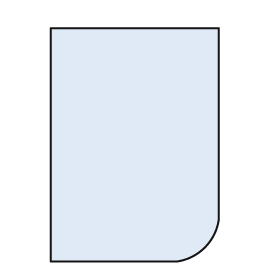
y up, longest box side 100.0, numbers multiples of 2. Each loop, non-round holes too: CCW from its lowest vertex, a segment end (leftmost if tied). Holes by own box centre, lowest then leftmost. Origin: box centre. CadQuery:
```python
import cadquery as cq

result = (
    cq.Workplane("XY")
    .moveTo(-36.0, -50.0)
    .lineTo(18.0, -50.0)
    .threePointArc((30.0, -44.0), (36.0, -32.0))
    .lineTo(36.0, 50.0)
    .lineTo(-36.0, 50.0)
    .close()
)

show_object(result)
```